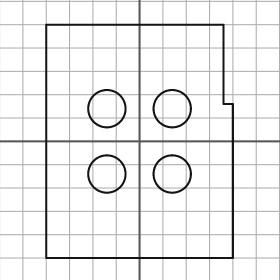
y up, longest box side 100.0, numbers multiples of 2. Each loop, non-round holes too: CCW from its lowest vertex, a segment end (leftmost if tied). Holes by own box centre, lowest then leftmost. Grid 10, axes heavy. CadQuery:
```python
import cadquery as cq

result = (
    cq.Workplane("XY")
    .moveTo(-40.0, -50.0)
    .lineTo(40.0, -50.0)
    .lineTo(40.0, 16.0)
    .lineTo(36.0, 16.0)
    .lineTo(36.0, 50.0)
    .lineTo(-40.0, 50.0)
    .close()
    .moveTo(-14.0, -14.0)
    .circle(8.0)
    .moveTo(14.0, -14.0)
    .circle(8.0)
    .moveTo(-14.0, 14.0)
    .circle(8.0)
    .moveTo(14.0, 14.0)
    .circle(8.0)
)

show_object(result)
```